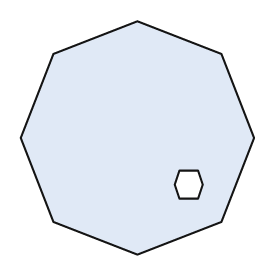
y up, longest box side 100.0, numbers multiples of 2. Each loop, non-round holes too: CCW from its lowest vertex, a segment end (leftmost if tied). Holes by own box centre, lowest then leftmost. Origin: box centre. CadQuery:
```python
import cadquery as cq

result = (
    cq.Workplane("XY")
    .moveTo(0.0, -50.0)
    .lineTo(36.0, -36.0)
    .lineTo(50.0, 0.0)
    .lineTo(36.0, 36.0)
    .lineTo(0.0, 50.0)
    .lineTo(-36.0, 36.0)
    .lineTo(-50.0, 0.0)
    .lineTo(-36.0, -36.0)
    .close()
    .moveTo(18.0, -26.0)
    .lineTo(26.0, -26.0)
    .lineTo(28.0, -20.0)
    .lineTo(26.0, -14.0)
    .lineTo(18.0, -14.0)
    .lineTo(16.0, -20.0)
    .close()
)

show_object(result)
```